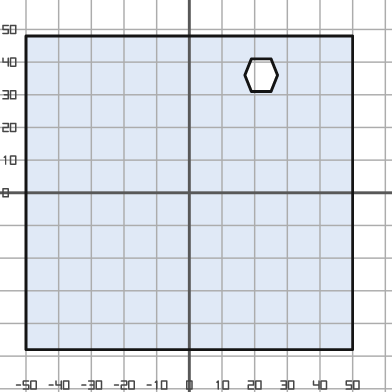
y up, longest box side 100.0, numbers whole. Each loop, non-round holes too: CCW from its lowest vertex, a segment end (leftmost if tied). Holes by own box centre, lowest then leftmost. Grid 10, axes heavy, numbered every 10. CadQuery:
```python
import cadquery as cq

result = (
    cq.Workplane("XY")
    .moveTo(-50.0, -48.0)
    .lineTo(50.0, -48.0)
    .lineTo(50.0, 48.0)
    .lineTo(-50.0, 48.0)
    .close()
    .moveTo(19.0, 31.0)
    .lineTo(25.0, 31.0)
    .lineTo(27.0, 36.0)
    .lineTo(25.0, 41.0)
    .lineTo(19.0, 41.0)
    .lineTo(17.0, 36.0)
    .close()
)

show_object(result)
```